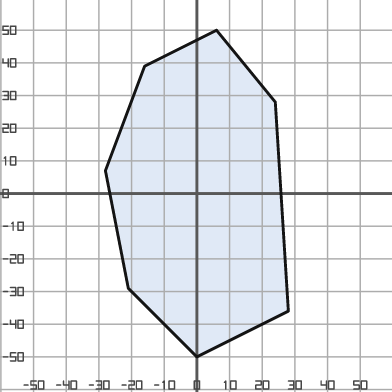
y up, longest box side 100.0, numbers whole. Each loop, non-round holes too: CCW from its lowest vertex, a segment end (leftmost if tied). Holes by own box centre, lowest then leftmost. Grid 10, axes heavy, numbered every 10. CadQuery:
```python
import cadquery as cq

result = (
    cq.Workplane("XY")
    .moveTo(0.0, -50.0)
    .lineTo(28.0, -36.0)
    .lineTo(24.0, 28.0)
    .lineTo(6.0, 50.0)
    .lineTo(-16.0, 39.0)
    .lineTo(-28.0, 7.0)
    .lineTo(-21.0, -29.0)
    .close()
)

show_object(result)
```